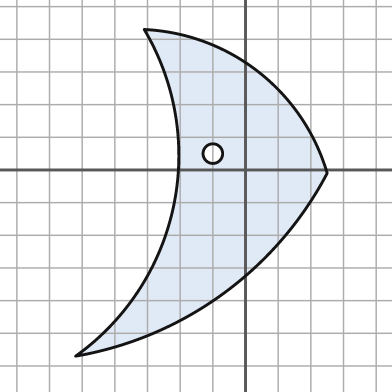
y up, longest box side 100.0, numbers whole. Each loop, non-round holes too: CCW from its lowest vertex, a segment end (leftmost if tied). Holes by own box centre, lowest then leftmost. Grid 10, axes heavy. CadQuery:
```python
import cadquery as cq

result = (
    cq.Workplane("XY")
    .moveTo(-52.0, -57.0)
    .threePointArc((-7.0, -38.0), (25.0, -1.0))
    .threePointArc((4.0, 30.0), (-31.0, 43.0))
    .threePointArc((-22.0, -11.0), (-52.0, -57.0))
    .close()
    .moveTo(-10.0, 5.0)
    .circle(3.0)
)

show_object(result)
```